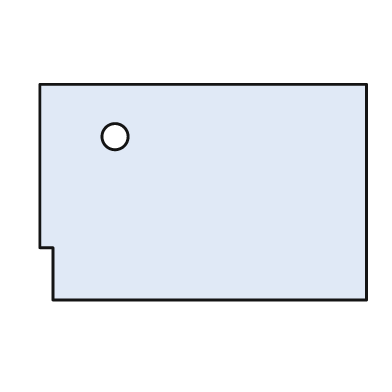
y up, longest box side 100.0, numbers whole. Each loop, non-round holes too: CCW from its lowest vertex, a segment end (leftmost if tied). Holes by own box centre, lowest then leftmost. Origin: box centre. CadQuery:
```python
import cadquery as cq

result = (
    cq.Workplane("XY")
    .moveTo(-46.0, -33.0)
    .lineTo(50.0, -33.0)
    .lineTo(50.0, 33.0)
    .lineTo(-50.0, 33.0)
    .lineTo(-50.0, -17.0)
    .lineTo(-46.0, -17.0)
    .close()
    .moveTo(-27.0, 17.0)
    .circle(4.0)
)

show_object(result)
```